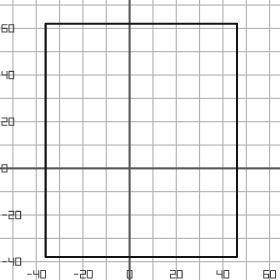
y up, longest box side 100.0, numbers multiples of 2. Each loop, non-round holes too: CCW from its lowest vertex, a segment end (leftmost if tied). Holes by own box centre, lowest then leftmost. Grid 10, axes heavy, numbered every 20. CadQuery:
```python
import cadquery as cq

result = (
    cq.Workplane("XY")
    .moveTo(-36.0, -38.0)
    .lineTo(46.0, -38.0)
    .lineTo(46.0, 62.0)
    .lineTo(-36.0, 62.0)
    .close()
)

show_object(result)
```